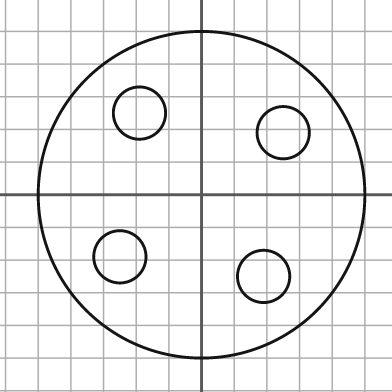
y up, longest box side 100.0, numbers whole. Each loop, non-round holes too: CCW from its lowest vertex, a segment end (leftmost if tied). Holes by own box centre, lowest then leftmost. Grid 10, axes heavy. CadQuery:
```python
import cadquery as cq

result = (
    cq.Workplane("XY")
    .moveTo(0.0, 0.0)
    .circle(50.0)
    .moveTo(19.0, -25.0)
    .circle(8.0)
    .moveTo(-25.0, -19.0)
    .circle(8.0)
    .moveTo(25.0, 19.0)
    .circle(8.0)
    .moveTo(-19.0, 25.0)
    .circle(8.0)
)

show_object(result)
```